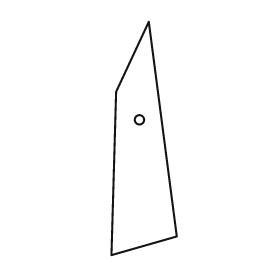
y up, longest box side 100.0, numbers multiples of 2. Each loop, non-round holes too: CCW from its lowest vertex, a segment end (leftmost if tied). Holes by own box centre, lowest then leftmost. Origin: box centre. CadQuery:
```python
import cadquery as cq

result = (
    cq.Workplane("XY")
    .moveTo(-14.0, -50.0)
    .lineTo(14.0, -42.0)
    .lineTo(2.0, 50.0)
    .lineTo(-12.0, 20.0)
    .close()
    .moveTo(-2.0, 8.0)
    .circle(2.0)
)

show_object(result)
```